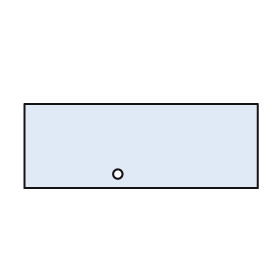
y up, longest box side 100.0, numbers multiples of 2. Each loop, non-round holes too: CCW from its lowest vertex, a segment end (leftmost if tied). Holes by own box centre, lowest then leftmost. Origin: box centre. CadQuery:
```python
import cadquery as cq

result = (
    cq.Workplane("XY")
    .moveTo(-50.0, -18.0)
    .lineTo(50.0, -18.0)
    .lineTo(50.0, 18.0)
    .lineTo(-50.0, 18.0)
    .close()
    .moveTo(-10.0, -12.0)
    .circle(2.0)
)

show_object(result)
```